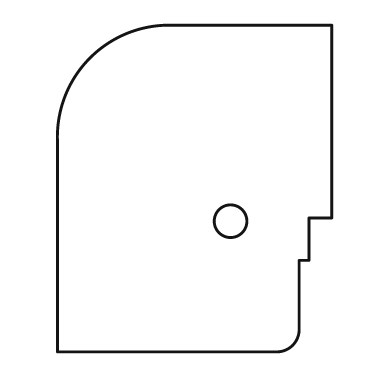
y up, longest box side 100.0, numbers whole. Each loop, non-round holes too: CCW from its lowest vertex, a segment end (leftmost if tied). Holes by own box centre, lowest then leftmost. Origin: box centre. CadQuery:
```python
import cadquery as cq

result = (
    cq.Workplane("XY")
    .moveTo(-42.0, -50.0)
    .lineTo(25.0, -50.0)
    .threePointArc((30.0, -48.0), (32.0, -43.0))
    .lineTo(32.0, -22.0)
    .lineTo(35.0, -22.0)
    .lineTo(35.0, -9.0)
    .lineTo(42.0, -9.0)
    .lineTo(42.0, 50.0)
    .lineTo(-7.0, 50.0)
    .threePointArc((-32.0, 40.0), (-42.0, 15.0))
    .close()
    .moveTo(11.0, -10.0)
    .circle(5.0)
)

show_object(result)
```